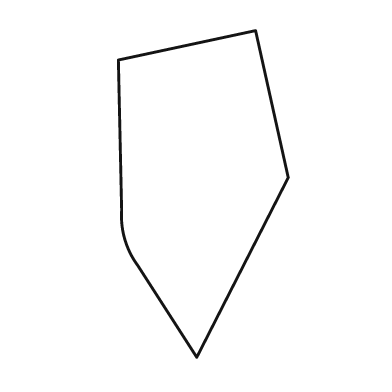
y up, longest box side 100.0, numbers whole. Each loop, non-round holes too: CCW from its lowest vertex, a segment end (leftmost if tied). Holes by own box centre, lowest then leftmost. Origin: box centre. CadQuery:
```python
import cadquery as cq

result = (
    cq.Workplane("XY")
    .moveTo(-2.0, -50.0)
    .lineTo(26.0, 5.0)
    .lineTo(16.0, 50.0)
    .lineTo(-26.0, 41.0)
    .lineTo(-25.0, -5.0)
    .threePointArc((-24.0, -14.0), (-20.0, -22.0))
    .close()
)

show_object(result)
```